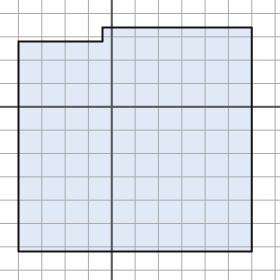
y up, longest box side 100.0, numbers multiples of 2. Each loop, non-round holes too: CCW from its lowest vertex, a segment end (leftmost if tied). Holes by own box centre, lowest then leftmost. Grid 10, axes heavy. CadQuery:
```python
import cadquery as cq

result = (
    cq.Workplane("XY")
    .moveTo(-40.0, -62.0)
    .lineTo(60.0, -62.0)
    .lineTo(60.0, 34.0)
    .lineTo(-4.0, 34.0)
    .lineTo(-4.0, 28.0)
    .lineTo(-40.0, 28.0)
    .close()
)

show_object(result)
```